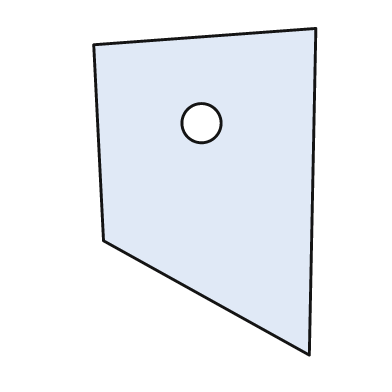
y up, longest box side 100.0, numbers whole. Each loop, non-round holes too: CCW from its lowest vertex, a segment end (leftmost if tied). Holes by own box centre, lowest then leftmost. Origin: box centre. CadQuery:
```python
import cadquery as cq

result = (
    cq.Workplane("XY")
    .moveTo(32.0, -50.0)
    .lineTo(34.0, 50.0)
    .lineTo(-34.0, 45.0)
    .lineTo(-31.0, -15.0)
    .close()
    .moveTo(-1.0, 21.0)
    .circle(6.0)
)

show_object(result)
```